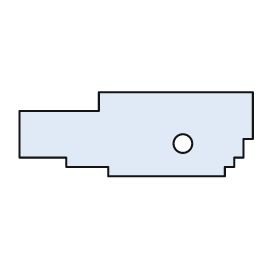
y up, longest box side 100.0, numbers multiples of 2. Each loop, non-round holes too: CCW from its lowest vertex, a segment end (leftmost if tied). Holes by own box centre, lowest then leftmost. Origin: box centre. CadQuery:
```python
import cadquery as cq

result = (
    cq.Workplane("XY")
    .moveTo(-12.0, -18.0)
    .lineTo(38.0, -18.0)
    .lineTo(38.0, -14.0)
    .lineTo(42.0, -14.0)
    .lineTo(42.0, -10.0)
    .lineTo(46.0, -10.0)
    .lineTo(46.0, -2.0)
    .lineTo(50.0, -2.0)
    .lineTo(50.0, 18.0)
    .lineTo(-16.0, 18.0)
    .lineTo(-16.0, 10.0)
    .lineTo(-50.0, 10.0)
    .lineTo(-50.0, -10.0)
    .lineTo(-30.0, -10.0)
    .lineTo(-30.0, -14.0)
    .lineTo(-12.0, -14.0)
    .close()
    .moveTo(20.0, -4.0)
    .circle(4.0)
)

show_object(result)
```